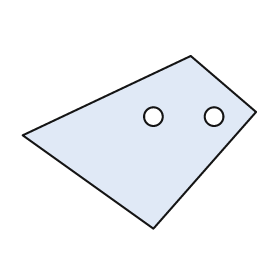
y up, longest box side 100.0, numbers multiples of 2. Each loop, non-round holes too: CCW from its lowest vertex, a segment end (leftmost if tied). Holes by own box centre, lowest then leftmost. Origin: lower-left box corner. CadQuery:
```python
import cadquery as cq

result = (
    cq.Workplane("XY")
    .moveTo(56.0, 0.0)
    .lineTo(100.0, 50.0)
    .lineTo(72.0, 74.0)
    .lineTo(0.0, 40.0)
    .close()
    .moveTo(56.0, 48.0)
    .circle(4.0)
    .moveTo(82.0, 48.0)
    .circle(4.0)
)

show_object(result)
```